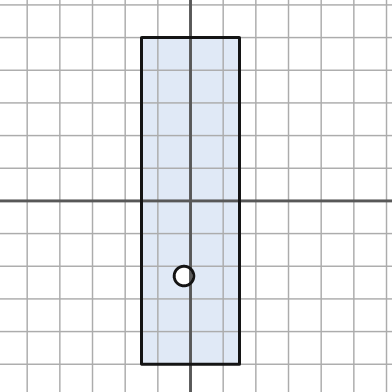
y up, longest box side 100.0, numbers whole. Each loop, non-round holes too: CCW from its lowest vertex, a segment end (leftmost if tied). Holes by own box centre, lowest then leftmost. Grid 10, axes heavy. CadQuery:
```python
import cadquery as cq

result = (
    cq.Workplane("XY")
    .moveTo(-15.0, -50.0)
    .lineTo(15.0, -50.0)
    .lineTo(15.0, 50.0)
    .lineTo(-15.0, 50.0)
    .close()
    .moveTo(-2.0, -23.0)
    .circle(3.0)
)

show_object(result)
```